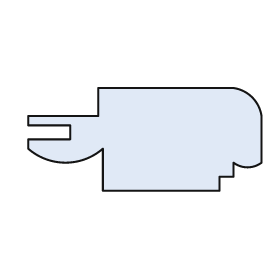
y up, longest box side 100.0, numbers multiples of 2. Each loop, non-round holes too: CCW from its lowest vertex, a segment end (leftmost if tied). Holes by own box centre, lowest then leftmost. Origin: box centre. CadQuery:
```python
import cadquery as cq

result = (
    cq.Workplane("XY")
    .moveTo(-18.0, -22.0)
    .lineTo(32.0, -22.0)
    .lineTo(32.0, -16.0)
    .lineTo(38.0, -16.0)
    .lineTo(38.0, -10.0)
    .threePointArc((44.0, -12.0), (50.0, -10.0))
    .lineTo(50.0, 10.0)
    .threePointArc((46.0, 18.0), (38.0, 22.0))
    .lineTo(-20.0, 22.0)
    .lineTo(-20.0, 10.0)
    .lineTo(-50.0, 10.0)
    .lineTo(-50.0, 6.0)
    .lineTo(-32.0, 6.0)
    .lineTo(-32.0, 0.0)
    .lineTo(-50.0, 0.0)
    .lineTo(-50.0, -4.0)
    .threePointArc((-34.0, -10.0), (-18.0, -4.0))
    .close()
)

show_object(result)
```